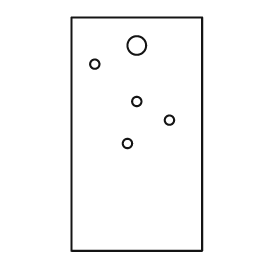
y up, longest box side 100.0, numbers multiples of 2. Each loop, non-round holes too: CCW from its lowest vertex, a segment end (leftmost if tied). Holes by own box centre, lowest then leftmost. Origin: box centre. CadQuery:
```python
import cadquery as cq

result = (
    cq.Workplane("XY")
    .moveTo(-28.0, -50.0)
    .lineTo(28.0, -50.0)
    .lineTo(28.0, 50.0)
    .lineTo(-28.0, 50.0)
    .close()
    .moveTo(-4.0, -4.0)
    .circle(2.0)
    .moveTo(14.0, 6.0)
    .circle(2.0)
    .moveTo(0.0, 14.0)
    .circle(2.0)
    .moveTo(-18.0, 30.0)
    .circle(2.0)
    .moveTo(0.0, 38.0)
    .circle(4.0)
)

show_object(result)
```